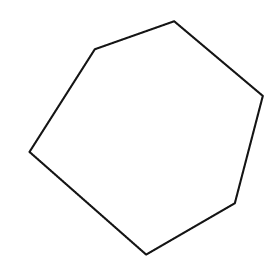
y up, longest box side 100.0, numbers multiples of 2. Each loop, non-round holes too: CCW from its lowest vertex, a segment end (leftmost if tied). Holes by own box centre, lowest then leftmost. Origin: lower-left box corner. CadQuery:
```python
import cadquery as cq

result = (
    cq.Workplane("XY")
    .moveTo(50.0, 0.0)
    .lineTo(88.0, 22.0)
    .lineTo(100.0, 68.0)
    .lineTo(62.0, 100.0)
    .lineTo(28.0, 88.0)
    .lineTo(0.0, 44.0)
    .close()
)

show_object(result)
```